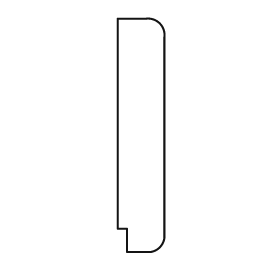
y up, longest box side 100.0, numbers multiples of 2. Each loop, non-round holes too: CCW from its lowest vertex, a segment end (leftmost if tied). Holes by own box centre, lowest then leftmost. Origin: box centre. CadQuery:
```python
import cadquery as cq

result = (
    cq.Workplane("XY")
    .moveTo(-6.0, -50.0)
    .lineTo(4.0, -50.0)
    .threePointArc((8.0, -48.0), (10.0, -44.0))
    .lineTo(10.0, 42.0)
    .threePointArc((8.0, 48.0), (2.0, 50.0))
    .lineTo(-10.0, 50.0)
    .lineTo(-10.0, -40.0)
    .lineTo(-6.0, -40.0)
    .close()
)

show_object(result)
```